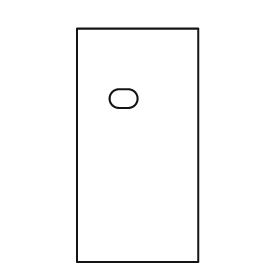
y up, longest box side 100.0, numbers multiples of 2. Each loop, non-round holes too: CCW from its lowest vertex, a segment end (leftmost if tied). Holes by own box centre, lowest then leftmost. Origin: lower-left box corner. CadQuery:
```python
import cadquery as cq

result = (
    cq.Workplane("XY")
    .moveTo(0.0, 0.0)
    .lineTo(52.0, 0.0)
    .lineTo(52.0, 100.0)
    .lineTo(0.0, 100.0)
    .close()
    .moveTo(18.0, 66.0)
    .lineTo(22.0, 66.0)
    .threePointArc((26.0, 70.0), (22.0, 74.0))
    .lineTo(18.0, 74.0)
    .threePointArc((14.0, 70.0), (18.0, 66.0))
    .close()
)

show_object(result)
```